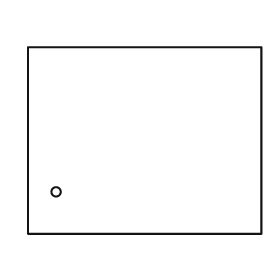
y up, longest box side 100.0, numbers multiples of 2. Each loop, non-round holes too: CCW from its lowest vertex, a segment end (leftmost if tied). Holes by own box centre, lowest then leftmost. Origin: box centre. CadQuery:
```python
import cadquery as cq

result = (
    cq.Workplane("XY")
    .moveTo(-50.0, -40.0)
    .lineTo(50.0, -40.0)
    .lineTo(50.0, 40.0)
    .lineTo(-50.0, 40.0)
    .close()
    .moveTo(-38.0, -22.0)
    .circle(2.0)
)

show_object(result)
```